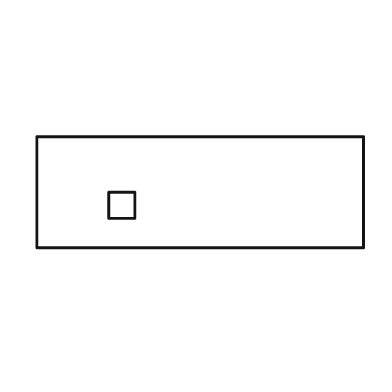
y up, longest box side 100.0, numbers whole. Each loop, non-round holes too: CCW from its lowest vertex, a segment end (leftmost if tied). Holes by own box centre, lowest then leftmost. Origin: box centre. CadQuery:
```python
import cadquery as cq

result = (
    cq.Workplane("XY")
    .moveTo(-50.0, -17.0)
    .lineTo(50.0, -17.0)
    .lineTo(50.0, 17.0)
    .lineTo(-50.0, 17.0)
    .close()
    .moveTo(-28.0, -8.0)
    .lineTo(-20.0, -8.0)
    .lineTo(-20.0, 0.0)
    .lineTo(-28.0, 0.0)
    .close()
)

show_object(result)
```